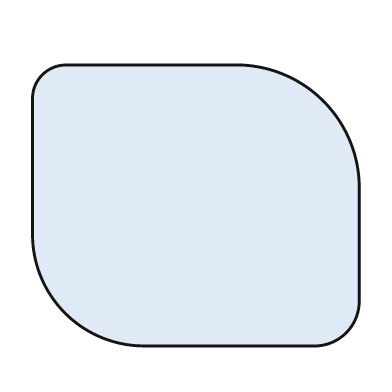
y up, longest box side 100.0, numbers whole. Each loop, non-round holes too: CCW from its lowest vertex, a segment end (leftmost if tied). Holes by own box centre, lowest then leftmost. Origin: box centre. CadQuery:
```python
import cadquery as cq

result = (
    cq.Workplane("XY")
    .moveTo(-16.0, -43.0)
    .lineTo(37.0, -43.0)
    .threePointArc((46.0, -39.0), (50.0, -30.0))
    .lineTo(50.0, 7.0)
    .threePointArc((39.0, 32.0), (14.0, 43.0))
    .lineTo(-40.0, 43.0)
    .threePointArc((-47.0, 40.0), (-50.0, 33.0))
    .lineTo(-50.0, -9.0)
    .threePointArc((-40.0, -33.0), (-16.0, -43.0))
    .close()
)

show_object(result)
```